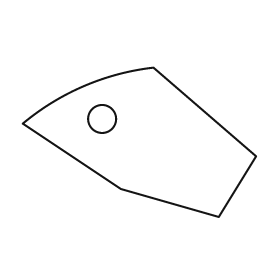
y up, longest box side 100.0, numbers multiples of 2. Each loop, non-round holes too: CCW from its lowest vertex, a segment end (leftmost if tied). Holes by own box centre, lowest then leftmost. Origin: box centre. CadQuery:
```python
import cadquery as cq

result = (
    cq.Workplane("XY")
    .moveTo(34.0, -32.0)
    .lineTo(50.0, -6.0)
    .lineTo(6.0, 32.0)
    .threePointArc((-24.0, 24.0), (-50.0, 8.0))
    .lineTo(-8.0, -20.0)
    .close()
    .moveTo(-16.0, 10.0)
    .circle(6.0)
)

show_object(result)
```